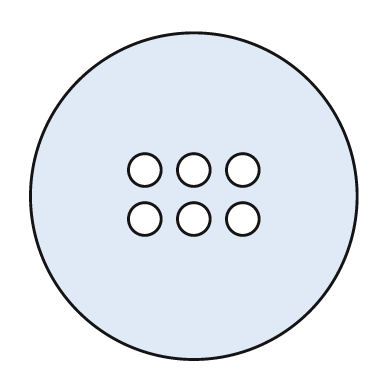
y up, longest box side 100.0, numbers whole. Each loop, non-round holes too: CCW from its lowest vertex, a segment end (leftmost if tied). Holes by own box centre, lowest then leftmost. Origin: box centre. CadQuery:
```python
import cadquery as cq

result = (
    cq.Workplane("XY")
    .moveTo(0.0, 0.0)
    .circle(50.0)
    .moveTo(-15.0, -7.0)
    .circle(5.0)
    .moveTo(0.0, -7.0)
    .circle(5.0)
    .moveTo(15.0, -7.0)
    .circle(5.0)
    .moveTo(-15.0, 8.0)
    .circle(5.0)
    .moveTo(0.0, 8.0)
    .circle(5.0)
    .moveTo(15.0, 8.0)
    .circle(5.0)
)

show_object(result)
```